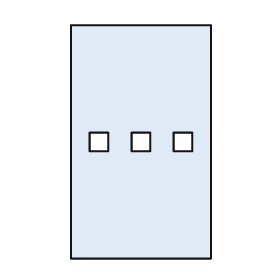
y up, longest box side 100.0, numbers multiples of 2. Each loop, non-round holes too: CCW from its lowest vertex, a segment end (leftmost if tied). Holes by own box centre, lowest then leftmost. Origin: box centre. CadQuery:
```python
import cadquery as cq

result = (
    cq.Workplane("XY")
    .moveTo(-30.0, -50.0)
    .lineTo(30.0, -50.0)
    .lineTo(30.0, 50.0)
    .lineTo(-30.0, 50.0)
    .close()
    .moveTo(-22.0, -4.0)
    .lineTo(-14.0, -4.0)
    .lineTo(-14.0, 4.0)
    .lineTo(-22.0, 4.0)
    .close()
    .moveTo(-4.0, -4.0)
    .lineTo(4.0, -4.0)
    .lineTo(4.0, 4.0)
    .lineTo(-4.0, 4.0)
    .close()
    .moveTo(14.0, -4.0)
    .lineTo(22.0, -4.0)
    .lineTo(22.0, 4.0)
    .lineTo(14.0, 4.0)
    .close()
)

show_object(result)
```